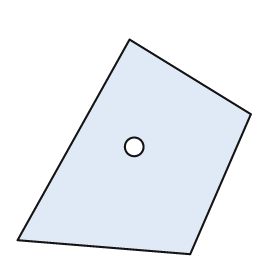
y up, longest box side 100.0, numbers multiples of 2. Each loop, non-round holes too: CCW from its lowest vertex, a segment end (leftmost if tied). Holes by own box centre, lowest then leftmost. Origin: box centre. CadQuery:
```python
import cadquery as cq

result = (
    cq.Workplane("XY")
    .moveTo(24.0, -46.0)
    .lineTo(50.0, 14.0)
    .lineTo(-2.0, 46.0)
    .lineTo(-50.0, -40.0)
    .close()
    .moveTo(0.0, 0.0)
    .circle(4.0)
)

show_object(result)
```